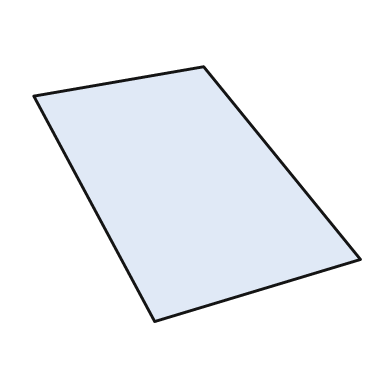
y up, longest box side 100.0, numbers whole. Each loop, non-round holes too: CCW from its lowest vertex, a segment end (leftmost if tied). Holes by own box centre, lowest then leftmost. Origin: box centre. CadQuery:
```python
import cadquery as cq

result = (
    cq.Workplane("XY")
    .moveTo(-13.0, -39.0)
    .lineTo(50.0, -20.0)
    .lineTo(2.0, 39.0)
    .lineTo(-50.0, 30.0)
    .close()
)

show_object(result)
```